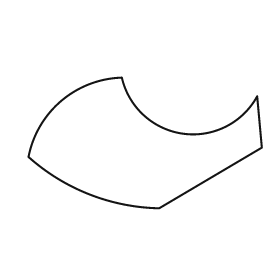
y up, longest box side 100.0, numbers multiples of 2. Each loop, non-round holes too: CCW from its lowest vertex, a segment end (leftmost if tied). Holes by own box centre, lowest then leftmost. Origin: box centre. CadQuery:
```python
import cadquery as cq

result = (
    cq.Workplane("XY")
    .moveTo(6.0, -28.0)
    .lineTo(50.0, -2.0)
    .lineTo(48.0, 20.0)
    .threePointArc((16.0, 4.0), (-10.0, 28.0))
    .threePointArc((-36.0, 18.0), (-50.0, -6.0))
    .threePointArc((-24.0, -22.0), (6.0, -28.0))
    .close()
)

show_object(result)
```